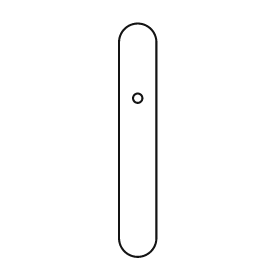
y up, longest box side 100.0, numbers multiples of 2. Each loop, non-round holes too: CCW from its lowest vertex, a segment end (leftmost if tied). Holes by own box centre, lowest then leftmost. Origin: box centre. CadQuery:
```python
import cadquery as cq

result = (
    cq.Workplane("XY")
    .moveTo(-8.0, -42.0)
    .threePointArc((0.0, -50.0), (8.0, -42.0))
    .lineTo(8.0, 42.0)
    .threePointArc((0.0, 50.0), (-8.0, 42.0))
    .close()
    .moveTo(0.0, 18.0)
    .circle(2.0)
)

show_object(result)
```